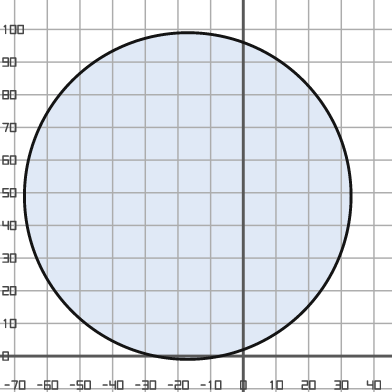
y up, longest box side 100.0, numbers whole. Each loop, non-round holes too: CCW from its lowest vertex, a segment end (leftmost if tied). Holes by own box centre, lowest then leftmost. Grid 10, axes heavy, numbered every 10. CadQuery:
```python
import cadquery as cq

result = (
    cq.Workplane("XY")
    .moveTo(-17.0, 49.0)
    .circle(50.0)
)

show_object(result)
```